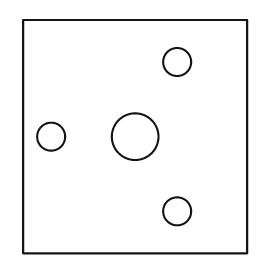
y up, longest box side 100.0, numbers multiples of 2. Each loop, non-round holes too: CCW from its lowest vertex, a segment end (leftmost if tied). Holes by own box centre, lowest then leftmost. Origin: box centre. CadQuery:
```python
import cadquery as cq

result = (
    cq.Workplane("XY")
    .moveTo(-48.0, -50.0)
    .lineTo(48.0, -50.0)
    .lineTo(48.0, 50.0)
    .lineTo(-48.0, 50.0)
    .close()
    .moveTo(18.0, -32.0)
    .circle(6.0)
    .moveTo(-36.0, 0.0)
    .circle(6.0)
    .moveTo(0.0, 0.0)
    .circle(10.0)
    .moveTo(18.0, 32.0)
    .circle(6.0)
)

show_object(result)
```